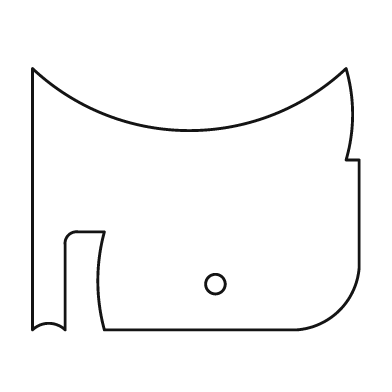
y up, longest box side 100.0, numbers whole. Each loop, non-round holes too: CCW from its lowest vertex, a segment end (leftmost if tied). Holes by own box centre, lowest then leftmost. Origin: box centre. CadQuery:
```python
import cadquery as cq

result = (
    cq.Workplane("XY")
    .moveTo(-50.0, -40.0)
    .threePointArc((-45.0, -38.0), (-40.0, -40.0))
    .lineTo(-40.0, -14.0)
    .threePointArc((-39.0, -11.0), (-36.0, -10.0))
    .lineTo(-28.0, -10.0)
    .threePointArc((-30.0, -25.0), (-28.0, -40.0))
    .lineTo(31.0, -40.0)
    .threePointArc((44.0, -34.0), (50.0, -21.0))
    .lineTo(50.0, 12.0)
    .lineTo(46.0, 12.0)
    .threePointArc((48.0, 26.0), (46.0, 40.0))
    .threePointArc((-2.0, 21.0), (-50.0, 40.0))
    .close()
    .moveTo(6.0, -26.0)
    .circle(3.0)
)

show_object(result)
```